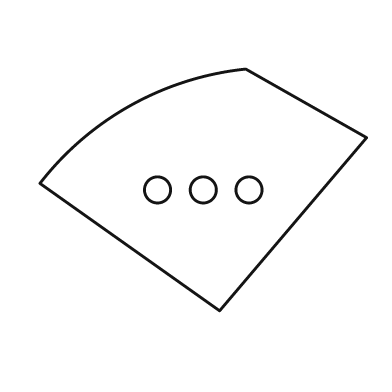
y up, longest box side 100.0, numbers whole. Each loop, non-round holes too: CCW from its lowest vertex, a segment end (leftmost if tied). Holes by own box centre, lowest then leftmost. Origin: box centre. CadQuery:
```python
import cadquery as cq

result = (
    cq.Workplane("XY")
    .moveTo(5.0, -37.0)
    .lineTo(50.0, 16.0)
    .lineTo(13.0, 37.0)
    .threePointArc((-22.0, 26.0), (-50.0, 2.0))
    .close()
    .moveTo(-14.0, 0.0)
    .circle(4.0)
    .moveTo(0.0, 0.0)
    .circle(4.0)
    .moveTo(14.0, 0.0)
    .circle(4.0)
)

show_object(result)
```